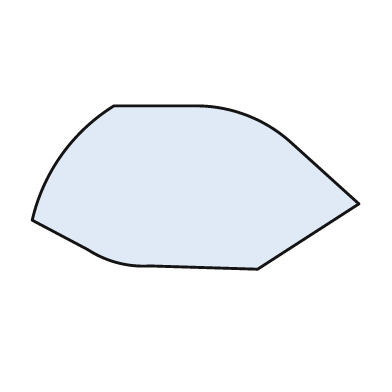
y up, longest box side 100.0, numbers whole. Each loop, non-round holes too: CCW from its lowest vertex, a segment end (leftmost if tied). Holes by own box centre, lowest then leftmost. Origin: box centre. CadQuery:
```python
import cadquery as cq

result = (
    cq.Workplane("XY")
    .moveTo(19.0, -25.0)
    .lineTo(50.0, -5.0)
    .lineTo(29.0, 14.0)
    .threePointArc((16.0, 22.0), (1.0, 25.0))
    .lineTo(-25.0, 25.0)
    .threePointArc((-41.0, 10.0), (-50.0, -10.0))
    .lineTo(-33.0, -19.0)
    .threePointArc((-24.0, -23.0), (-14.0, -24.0))
    .close()
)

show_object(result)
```